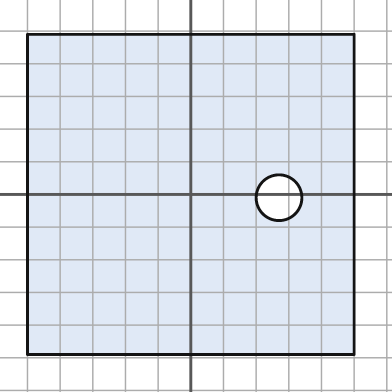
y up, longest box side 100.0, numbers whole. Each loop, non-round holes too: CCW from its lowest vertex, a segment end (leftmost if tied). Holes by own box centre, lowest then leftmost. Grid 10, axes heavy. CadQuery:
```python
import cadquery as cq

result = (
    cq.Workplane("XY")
    .moveTo(-50.0, -49.0)
    .lineTo(50.0, -49.0)
    .lineTo(50.0, 49.0)
    .lineTo(-50.0, 49.0)
    .close()
    .moveTo(27.0, -1.0)
    .circle(7.0)
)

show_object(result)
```